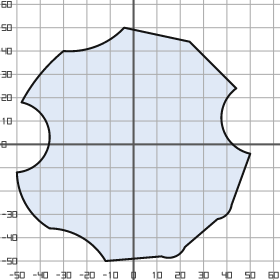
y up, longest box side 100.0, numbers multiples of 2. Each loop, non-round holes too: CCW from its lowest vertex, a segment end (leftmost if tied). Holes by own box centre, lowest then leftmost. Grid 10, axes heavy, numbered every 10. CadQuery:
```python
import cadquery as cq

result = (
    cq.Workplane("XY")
    .moveTo(-12.0, -50.0)
    .lineTo(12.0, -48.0)
    .threePointArc((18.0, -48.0), (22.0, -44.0))
    .lineTo(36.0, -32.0)
    .threePointArc((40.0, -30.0), (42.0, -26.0))
    .lineTo(50.0, -4.0)
    .threePointArc((38.0, 8.0), (44.0, 24.0))
    .lineTo(24.0, 44.0)
    .lineTo(-4.0, 50.0)
    .threePointArc((-16.0, 42.0), (-30.0, 40.0))
    .threePointArc((-40.0, 30.0), (-48.0, 18.0))
    .threePointArc((-36.0, 2.0), (-50.0, -12.0))
    .threePointArc((-46.0, -26.0), (-36.0, -36.0))
    .threePointArc((-22.0, -40.0), (-12.0, -50.0))
    .close()
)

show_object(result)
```